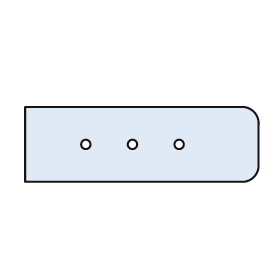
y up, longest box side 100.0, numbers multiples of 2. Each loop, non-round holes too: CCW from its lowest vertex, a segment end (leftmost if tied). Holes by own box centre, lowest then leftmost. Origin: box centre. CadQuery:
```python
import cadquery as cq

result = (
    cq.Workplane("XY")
    .moveTo(-50.0, -16.0)
    .lineTo(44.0, -16.0)
    .threePointArc((48.0, -14.0), (50.0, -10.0))
    .lineTo(50.0, 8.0)
    .threePointArc((48.0, 14.0), (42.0, 16.0))
    .lineTo(-50.0, 16.0)
    .close()
    .moveTo(-24.0, 0.0)
    .circle(2.0)
    .moveTo(-4.0, 0.0)
    .circle(2.0)
    .moveTo(16.0, 0.0)
    .circle(2.0)
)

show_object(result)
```